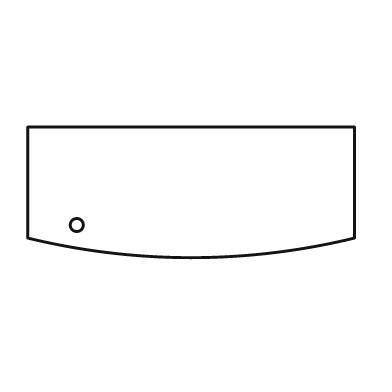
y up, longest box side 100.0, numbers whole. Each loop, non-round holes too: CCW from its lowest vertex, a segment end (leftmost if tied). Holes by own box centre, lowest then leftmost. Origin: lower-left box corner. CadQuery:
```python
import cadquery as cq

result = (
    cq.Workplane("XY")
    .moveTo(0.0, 6.0)
    .threePointArc((50.0, 0.0), (100.0, 6.0))
    .lineTo(100.0, 40.0)
    .lineTo(0.0, 40.0)
    .close()
    .moveTo(15.0, 10.0)
    .circle(2.0)
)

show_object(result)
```